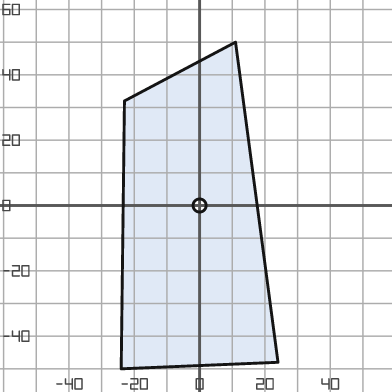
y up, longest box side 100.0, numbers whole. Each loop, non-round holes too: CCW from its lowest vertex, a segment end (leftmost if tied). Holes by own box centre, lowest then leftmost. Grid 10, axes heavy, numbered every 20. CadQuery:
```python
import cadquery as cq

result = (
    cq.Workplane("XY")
    .moveTo(-24.0, -50.0)
    .lineTo(24.0, -48.0)
    .lineTo(11.0, 50.0)
    .lineTo(-23.0, 32.0)
    .close()
    .moveTo(0.0, 0.0)
    .circle(2.0)
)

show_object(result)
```